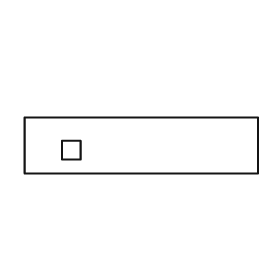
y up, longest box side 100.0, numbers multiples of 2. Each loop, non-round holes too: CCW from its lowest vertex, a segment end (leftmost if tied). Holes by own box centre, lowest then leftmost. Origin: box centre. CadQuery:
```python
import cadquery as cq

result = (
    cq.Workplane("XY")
    .moveTo(-50.0, -12.0)
    .lineTo(50.0, -12.0)
    .lineTo(50.0, 12.0)
    .lineTo(-50.0, 12.0)
    .close()
    .moveTo(-34.0, -6.0)
    .lineTo(-26.0, -6.0)
    .lineTo(-26.0, 2.0)
    .lineTo(-34.0, 2.0)
    .close()
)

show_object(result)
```